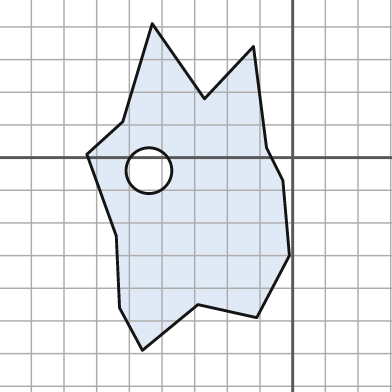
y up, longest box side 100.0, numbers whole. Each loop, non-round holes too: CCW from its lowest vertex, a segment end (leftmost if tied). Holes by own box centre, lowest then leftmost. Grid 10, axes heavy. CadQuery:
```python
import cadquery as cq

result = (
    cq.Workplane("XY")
    .moveTo(-46.0, -59.0)
    .lineTo(-29.0, -45.0)
    .lineTo(-11.0, -49.0)
    .lineTo(-1.0, -30.0)
    .lineTo(-3.0, -7.0)
    .lineTo(-8.0, 3.0)
    .lineTo(-12.0, 34.0)
    .lineTo(-27.0, 18.0)
    .lineTo(-43.0, 41.0)
    .lineTo(-52.0, 11.0)
    .lineTo(-63.0, 1.0)
    .lineTo(-54.0, -24.0)
    .lineTo(-53.0, -46.0)
    .close()
    .moveTo(-44.0, -4.0)
    .circle(7.0)
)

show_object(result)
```